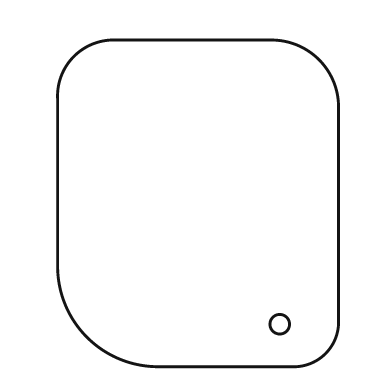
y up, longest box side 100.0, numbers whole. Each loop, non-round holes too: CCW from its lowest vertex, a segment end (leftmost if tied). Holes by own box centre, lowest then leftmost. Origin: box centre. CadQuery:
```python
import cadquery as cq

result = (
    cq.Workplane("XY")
    .moveTo(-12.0, -50.0)
    .lineTo(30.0, -50.0)
    .threePointArc((39.0, -46.0), (43.0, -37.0))
    .lineTo(43.0, 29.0)
    .threePointArc((37.0, 44.0), (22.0, 50.0))
    .lineTo(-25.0, 50.0)
    .threePointArc((-38.0, 45.0), (-43.0, 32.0))
    .lineTo(-43.0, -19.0)
    .threePointArc((-34.0, -41.0), (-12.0, -50.0))
    .close()
    .moveTo(25.0, -37.0)
    .circle(3.0)
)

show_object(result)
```